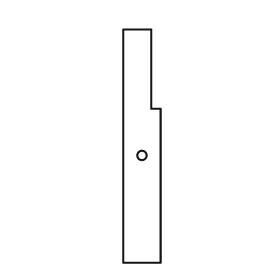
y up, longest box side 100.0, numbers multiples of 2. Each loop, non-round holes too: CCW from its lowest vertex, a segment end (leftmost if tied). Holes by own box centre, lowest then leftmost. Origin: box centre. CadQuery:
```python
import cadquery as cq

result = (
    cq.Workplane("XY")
    .moveTo(-8.0, -50.0)
    .lineTo(8.0, -50.0)
    .lineTo(8.0, 16.0)
    .lineTo(4.0, 16.0)
    .lineTo(4.0, 50.0)
    .lineTo(-8.0, 50.0)
    .close()
    .moveTo(0.0, -4.0)
    .circle(2.0)
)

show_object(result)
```